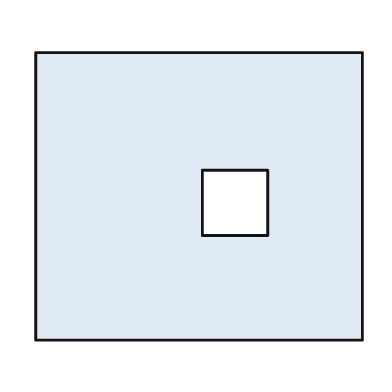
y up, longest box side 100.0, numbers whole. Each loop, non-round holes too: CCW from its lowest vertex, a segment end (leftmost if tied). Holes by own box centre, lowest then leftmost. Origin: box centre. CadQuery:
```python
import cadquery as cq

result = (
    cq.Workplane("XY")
    .moveTo(-50.0, -44.0)
    .lineTo(50.0, -44.0)
    .lineTo(50.0, 44.0)
    .lineTo(-50.0, 44.0)
    .close()
    .moveTo(1.0, -12.0)
    .lineTo(21.0, -12.0)
    .lineTo(21.0, 8.0)
    .lineTo(1.0, 8.0)
    .close()
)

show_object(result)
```